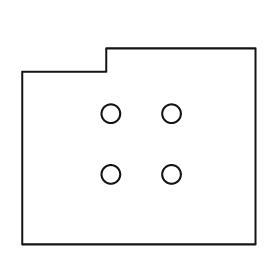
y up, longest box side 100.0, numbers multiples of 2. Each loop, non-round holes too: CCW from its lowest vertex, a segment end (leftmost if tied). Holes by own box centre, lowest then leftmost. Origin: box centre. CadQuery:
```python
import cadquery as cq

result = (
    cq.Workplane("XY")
    .moveTo(-50.0, -42.0)
    .lineTo(50.0, -42.0)
    .lineTo(50.0, 42.0)
    .lineTo(-14.0, 42.0)
    .lineTo(-14.0, 32.0)
    .lineTo(-50.0, 32.0)
    .close()
    .moveTo(-12.0, -12.0)
    .circle(4.0)
    .moveTo(14.0, -12.0)
    .circle(4.0)
    .moveTo(-12.0, 14.0)
    .circle(4.0)
    .moveTo(14.0, 14.0)
    .circle(4.0)
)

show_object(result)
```